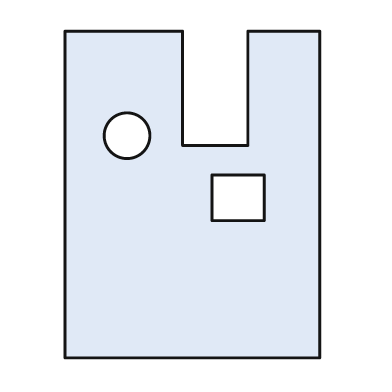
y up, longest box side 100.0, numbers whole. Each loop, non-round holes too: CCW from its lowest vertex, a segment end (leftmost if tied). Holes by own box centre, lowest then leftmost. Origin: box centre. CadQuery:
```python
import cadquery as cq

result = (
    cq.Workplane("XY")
    .moveTo(-39.0, -50.0)
    .lineTo(39.0, -50.0)
    .lineTo(39.0, 50.0)
    .lineTo(17.0, 50.0)
    .lineTo(17.0, 15.0)
    .lineTo(-3.0, 15.0)
    .lineTo(-3.0, 50.0)
    .lineTo(-39.0, 50.0)
    .close()
    .moveTo(6.0, -8.0)
    .lineTo(22.0, -8.0)
    .lineTo(22.0, 6.0)
    .lineTo(6.0, 6.0)
    .close()
    .moveTo(-20.0, 18.0)
    .circle(7.0)
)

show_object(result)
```